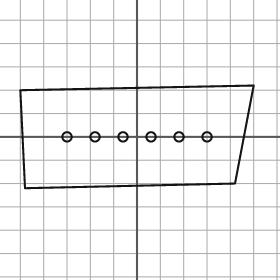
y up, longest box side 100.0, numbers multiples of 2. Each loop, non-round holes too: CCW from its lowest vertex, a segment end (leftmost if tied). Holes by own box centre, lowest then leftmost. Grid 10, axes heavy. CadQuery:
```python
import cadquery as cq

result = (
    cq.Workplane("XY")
    .moveTo(-48.0, -22.0)
    .lineTo(42.0, -20.0)
    .lineTo(50.0, 22.0)
    .lineTo(-50.0, 20.0)
    .close()
    .moveTo(-30.0, 0.0)
    .circle(2.0)
    .moveTo(-18.0, 0.0)
    .circle(2.0)
    .moveTo(-6.0, 0.0)
    .circle(2.0)
    .moveTo(6.0, 0.0)
    .circle(2.0)
    .moveTo(18.0, 0.0)
    .circle(2.0)
    .moveTo(30.0, 0.0)
    .circle(2.0)
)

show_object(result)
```